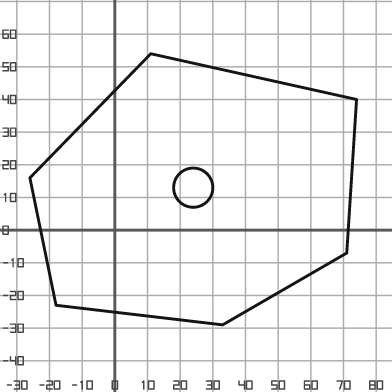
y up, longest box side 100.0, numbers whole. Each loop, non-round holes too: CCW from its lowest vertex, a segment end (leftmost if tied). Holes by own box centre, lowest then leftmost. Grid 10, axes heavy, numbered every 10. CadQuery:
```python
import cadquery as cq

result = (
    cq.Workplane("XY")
    .moveTo(33.0, -29.0)
    .lineTo(71.0, -7.0)
    .lineTo(74.0, 40.0)
    .lineTo(11.0, 54.0)
    .lineTo(-26.0, 16.0)
    .lineTo(-18.0, -23.0)
    .close()
    .moveTo(24.0, 13.0)
    .circle(6.0)
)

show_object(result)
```